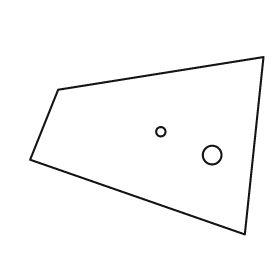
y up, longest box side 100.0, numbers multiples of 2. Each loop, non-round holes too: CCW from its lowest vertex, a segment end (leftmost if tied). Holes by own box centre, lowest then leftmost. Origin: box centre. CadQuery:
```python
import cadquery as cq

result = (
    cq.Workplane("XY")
    .moveTo(42.0, -38.0)
    .lineTo(50.0, 38.0)
    .lineTo(-38.0, 24.0)
    .lineTo(-50.0, -6.0)
    .close()
    .moveTo(28.0, -4.0)
    .circle(4.0)
    .moveTo(6.0, 6.0)
    .circle(2.0)
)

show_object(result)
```